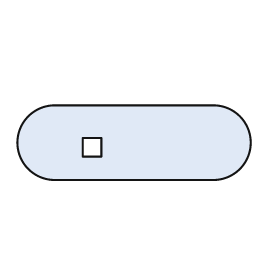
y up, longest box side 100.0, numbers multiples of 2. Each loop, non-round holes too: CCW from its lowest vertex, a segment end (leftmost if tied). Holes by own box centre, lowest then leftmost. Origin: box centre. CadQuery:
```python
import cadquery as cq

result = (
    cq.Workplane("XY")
    .moveTo(-34.0, -16.0)
    .lineTo(34.0, -16.0)
    .threePointArc((50.0, 0.0), (34.0, 16.0))
    .lineTo(-34.0, 16.0)
    .threePointArc((-50.0, 0.0), (-34.0, -16.0))
    .close()
    .moveTo(-22.0, -6.0)
    .lineTo(-14.0, -6.0)
    .lineTo(-14.0, 2.0)
    .lineTo(-22.0, 2.0)
    .close()
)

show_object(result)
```